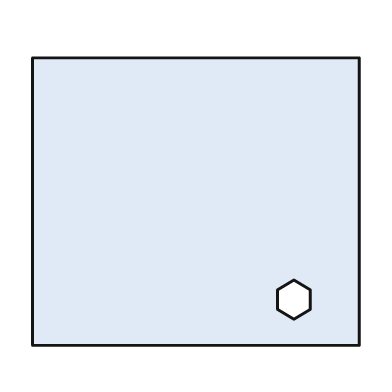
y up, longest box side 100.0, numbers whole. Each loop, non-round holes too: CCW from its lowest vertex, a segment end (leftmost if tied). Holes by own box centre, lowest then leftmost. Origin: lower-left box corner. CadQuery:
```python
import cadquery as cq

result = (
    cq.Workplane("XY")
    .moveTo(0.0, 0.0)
    .lineTo(100.0, 0.0)
    .lineTo(100.0, 88.0)
    .lineTo(0.0, 88.0)
    .close()
    .moveTo(80.0, 8.0)
    .lineTo(85.0, 11.0)
    .lineTo(85.0, 17.0)
    .lineTo(80.0, 20.0)
    .lineTo(75.0, 17.0)
    .lineTo(75.0, 11.0)
    .close()
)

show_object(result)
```